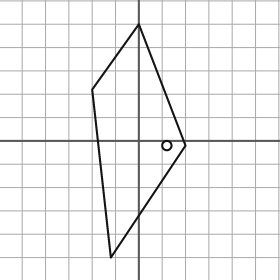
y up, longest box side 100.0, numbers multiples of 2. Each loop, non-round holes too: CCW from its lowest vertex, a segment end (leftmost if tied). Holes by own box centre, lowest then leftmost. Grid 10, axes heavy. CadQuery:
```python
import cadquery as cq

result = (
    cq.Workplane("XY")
    .moveTo(-12.0, -50.0)
    .lineTo(20.0, -2.0)
    .lineTo(0.0, 50.0)
    .lineTo(-20.0, 22.0)
    .close()
    .moveTo(12.0, -2.0)
    .circle(2.0)
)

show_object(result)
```